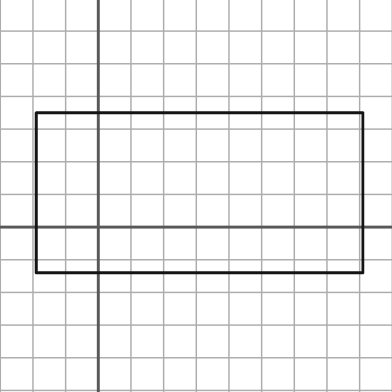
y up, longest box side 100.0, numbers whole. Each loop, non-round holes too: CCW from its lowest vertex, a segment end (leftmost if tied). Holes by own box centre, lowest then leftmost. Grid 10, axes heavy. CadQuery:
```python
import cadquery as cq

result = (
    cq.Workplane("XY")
    .moveTo(-19.0, -14.0)
    .lineTo(81.0, -14.0)
    .lineTo(81.0, 35.0)
    .lineTo(-19.0, 35.0)
    .close()
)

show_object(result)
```